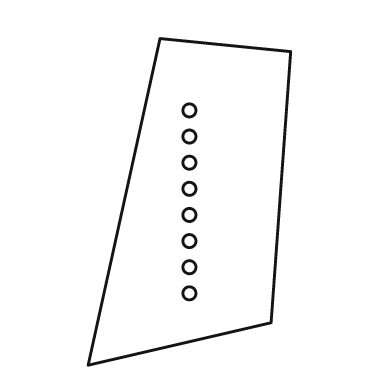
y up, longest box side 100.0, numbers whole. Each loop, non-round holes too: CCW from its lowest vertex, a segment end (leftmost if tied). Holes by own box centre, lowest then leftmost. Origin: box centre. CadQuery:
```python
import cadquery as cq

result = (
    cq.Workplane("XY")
    .moveTo(-31.0, -50.0)
    .lineTo(25.0, -37.0)
    .lineTo(31.0, 46.0)
    .lineTo(-9.0, 50.0)
    .close()
    .moveTo(0.0, -28.0)
    .circle(2.0)
    .moveTo(0.0, -20.0)
    .circle(2.0)
    .moveTo(0.0, -12.0)
    .circle(2.0)
    .moveTo(0.0, -4.0)
    .circle(2.0)
    .moveTo(0.0, 4.0)
    .circle(2.0)
    .moveTo(0.0, 12.0)
    .circle(2.0)
    .moveTo(0.0, 20.0)
    .circle(2.0)
    .moveTo(0.0, 28.0)
    .circle(2.0)
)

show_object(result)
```